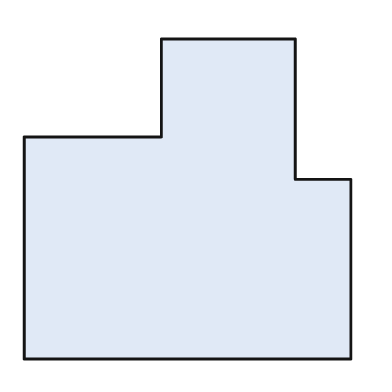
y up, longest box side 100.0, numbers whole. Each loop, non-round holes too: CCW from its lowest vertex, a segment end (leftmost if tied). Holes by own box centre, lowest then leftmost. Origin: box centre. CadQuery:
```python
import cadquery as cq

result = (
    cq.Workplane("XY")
    .moveTo(-50.0, -49.0)
    .lineTo(50.0, -49.0)
    .lineTo(50.0, 6.0)
    .lineTo(33.0, 6.0)
    .lineTo(33.0, 49.0)
    .lineTo(-8.0, 49.0)
    .lineTo(-8.0, 19.0)
    .lineTo(-50.0, 19.0)
    .close()
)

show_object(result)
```